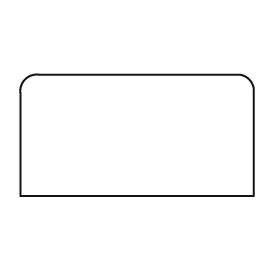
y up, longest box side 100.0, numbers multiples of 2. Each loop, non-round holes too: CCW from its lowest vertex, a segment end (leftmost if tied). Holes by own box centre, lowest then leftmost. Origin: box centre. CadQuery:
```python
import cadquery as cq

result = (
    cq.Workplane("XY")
    .moveTo(-50.0, -26.0)
    .lineTo(50.0, -26.0)
    .lineTo(50.0, 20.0)
    .threePointArc((48.0, 24.0), (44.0, 26.0))
    .lineTo(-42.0, 26.0)
    .threePointArc((-48.0, 24.0), (-50.0, 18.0))
    .close()
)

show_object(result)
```